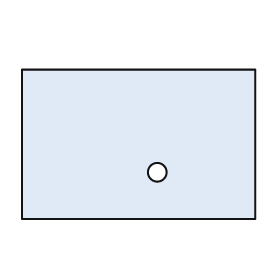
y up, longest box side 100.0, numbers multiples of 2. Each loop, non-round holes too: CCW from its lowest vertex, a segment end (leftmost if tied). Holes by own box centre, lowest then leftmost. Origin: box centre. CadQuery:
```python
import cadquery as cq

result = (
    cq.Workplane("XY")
    .moveTo(-50.0, -32.0)
    .lineTo(50.0, -32.0)
    .lineTo(50.0, 32.0)
    .lineTo(-50.0, 32.0)
    .close()
    .moveTo(8.0, -12.0)
    .circle(4.0)
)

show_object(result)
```